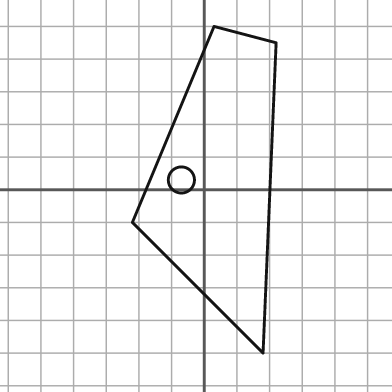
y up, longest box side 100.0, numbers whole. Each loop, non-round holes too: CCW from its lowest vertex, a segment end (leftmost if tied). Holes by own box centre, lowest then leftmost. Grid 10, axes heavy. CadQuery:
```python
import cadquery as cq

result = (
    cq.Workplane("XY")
    .moveTo(18.0, -50.0)
    .lineTo(22.0, 45.0)
    .lineTo(3.0, 50.0)
    .lineTo(-22.0, -10.0)
    .close()
    .moveTo(-7.0, 3.0)
    .circle(4.0)
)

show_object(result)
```